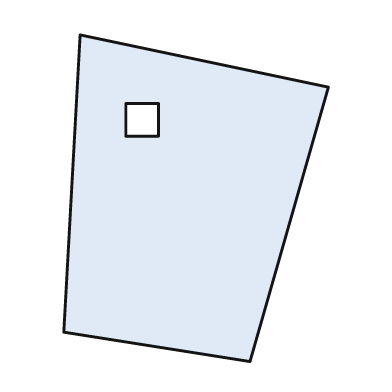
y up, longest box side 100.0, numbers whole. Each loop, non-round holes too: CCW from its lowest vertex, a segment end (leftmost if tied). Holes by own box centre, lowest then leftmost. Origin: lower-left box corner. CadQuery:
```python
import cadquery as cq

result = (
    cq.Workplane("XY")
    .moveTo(57.0, 0.0)
    .lineTo(81.0, 84.0)
    .lineTo(5.0, 100.0)
    .lineTo(0.0, 9.0)
    .close()
    .moveTo(19.0, 69.0)
    .lineTo(29.0, 69.0)
    .lineTo(29.0, 79.0)
    .lineTo(19.0, 79.0)
    .close()
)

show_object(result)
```